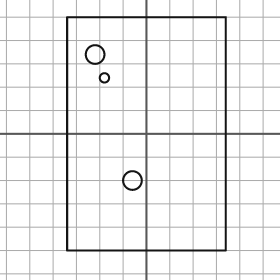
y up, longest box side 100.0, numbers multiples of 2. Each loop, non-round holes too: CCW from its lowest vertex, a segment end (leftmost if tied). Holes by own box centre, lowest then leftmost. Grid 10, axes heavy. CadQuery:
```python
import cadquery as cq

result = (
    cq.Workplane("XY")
    .moveTo(-34.0, -50.0)
    .lineTo(34.0, -50.0)
    .lineTo(34.0, 50.0)
    .lineTo(-34.0, 50.0)
    .close()
    .moveTo(-6.0, -20.0)
    .circle(4.0)
    .moveTo(-18.0, 24.0)
    .circle(2.0)
    .moveTo(-22.0, 34.0)
    .circle(4.0)
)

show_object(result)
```